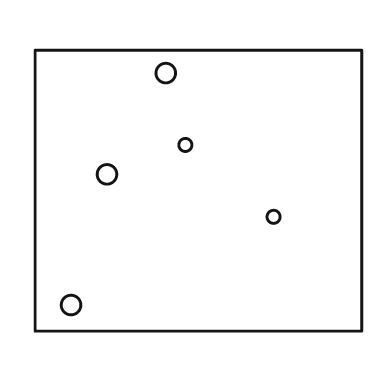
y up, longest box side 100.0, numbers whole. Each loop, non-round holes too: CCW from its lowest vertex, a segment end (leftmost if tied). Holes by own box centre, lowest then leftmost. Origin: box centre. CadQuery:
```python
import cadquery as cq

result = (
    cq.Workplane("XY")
    .moveTo(-50.0, -43.0)
    .lineTo(50.0, -43.0)
    .lineTo(50.0, 43.0)
    .lineTo(-50.0, 43.0)
    .close()
    .moveTo(-39.0, -35.0)
    .circle(3.0)
    .moveTo(23.0, -8.0)
    .circle(2.0)
    .moveTo(-28.0, 5.0)
    .circle(3.0)
    .moveTo(-4.0, 14.0)
    .circle(2.0)
    .moveTo(-10.0, 36.0)
    .circle(3.0)
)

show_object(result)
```